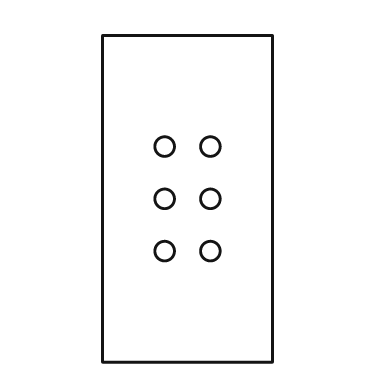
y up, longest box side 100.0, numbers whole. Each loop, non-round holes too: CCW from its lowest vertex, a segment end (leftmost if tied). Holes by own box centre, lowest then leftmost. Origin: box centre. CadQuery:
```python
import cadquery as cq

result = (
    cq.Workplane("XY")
    .moveTo(-26.0, -50.0)
    .lineTo(26.0, -50.0)
    .lineTo(26.0, 50.0)
    .lineTo(-26.0, 50.0)
    .close()
    .moveTo(-7.0, -16.0)
    .circle(3.0)
    .moveTo(7.0, -16.0)
    .circle(3.0)
    .moveTo(-7.0, 0.0)
    .circle(3.0)
    .moveTo(7.0, 0.0)
    .circle(3.0)
    .moveTo(-7.0, 16.0)
    .circle(3.0)
    .moveTo(7.0, 16.0)
    .circle(3.0)
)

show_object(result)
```